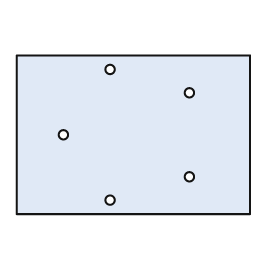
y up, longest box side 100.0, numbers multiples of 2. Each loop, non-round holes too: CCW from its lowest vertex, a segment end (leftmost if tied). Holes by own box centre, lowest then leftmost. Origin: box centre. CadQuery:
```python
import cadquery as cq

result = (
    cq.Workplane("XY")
    .moveTo(-50.0, -34.0)
    .lineTo(50.0, -34.0)
    .lineTo(50.0, 34.0)
    .lineTo(-50.0, 34.0)
    .close()
    .moveTo(-10.0, -28.0)
    .circle(2.0)
    .moveTo(24.0, -18.0)
    .circle(2.0)
    .moveTo(-30.0, 0.0)
    .circle(2.0)
    .moveTo(24.0, 18.0)
    .circle(2.0)
    .moveTo(-10.0, 28.0)
    .circle(2.0)
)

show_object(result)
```